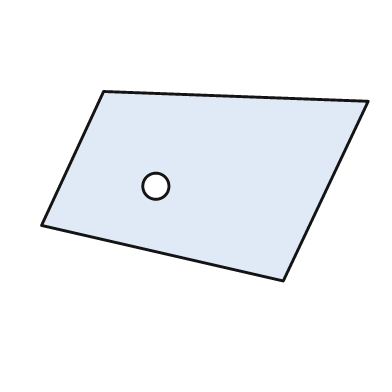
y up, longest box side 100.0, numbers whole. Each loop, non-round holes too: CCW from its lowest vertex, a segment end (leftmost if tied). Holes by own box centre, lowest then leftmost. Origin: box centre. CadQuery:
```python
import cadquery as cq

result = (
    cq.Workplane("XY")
    .moveTo(24.0, -29.0)
    .lineTo(50.0, 26.0)
    .lineTo(-31.0, 29.0)
    .lineTo(-50.0, -12.0)
    .close()
    .moveTo(-15.0, 0.0)
    .circle(4.0)
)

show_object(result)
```